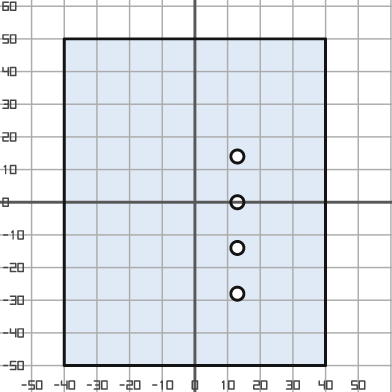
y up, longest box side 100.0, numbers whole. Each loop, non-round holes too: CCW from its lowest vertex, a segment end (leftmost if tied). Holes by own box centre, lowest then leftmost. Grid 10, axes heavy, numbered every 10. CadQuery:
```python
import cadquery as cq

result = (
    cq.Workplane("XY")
    .moveTo(-40.0, -50.0)
    .lineTo(40.0, -50.0)
    .lineTo(40.0, 50.0)
    .lineTo(-40.0, 50.0)
    .close()
    .moveTo(13.0, -28.0)
    .circle(2.0)
    .moveTo(13.0, -14.0)
    .circle(2.0)
    .moveTo(13.0, 0.0)
    .circle(2.0)
    .moveTo(13.0, 14.0)
    .circle(2.0)
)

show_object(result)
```